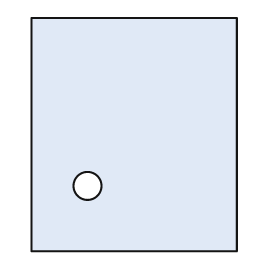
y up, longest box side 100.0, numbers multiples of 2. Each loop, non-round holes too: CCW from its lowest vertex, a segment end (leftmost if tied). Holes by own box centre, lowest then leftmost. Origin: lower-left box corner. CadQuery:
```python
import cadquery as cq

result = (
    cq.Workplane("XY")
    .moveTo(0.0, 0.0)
    .lineTo(88.0, 0.0)
    .lineTo(88.0, 100.0)
    .lineTo(0.0, 100.0)
    .close()
    .moveTo(24.0, 28.0)
    .circle(6.0)
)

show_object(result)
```